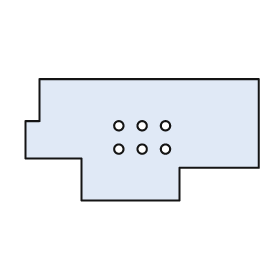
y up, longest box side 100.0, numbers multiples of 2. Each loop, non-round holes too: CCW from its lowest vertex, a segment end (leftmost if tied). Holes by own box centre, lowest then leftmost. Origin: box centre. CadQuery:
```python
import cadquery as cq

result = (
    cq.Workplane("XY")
    .moveTo(-26.0, -26.0)
    .lineTo(16.0, -26.0)
    .lineTo(16.0, -12.0)
    .lineTo(50.0, -12.0)
    .lineTo(50.0, 26.0)
    .lineTo(-44.0, 26.0)
    .lineTo(-44.0, 8.0)
    .lineTo(-50.0, 8.0)
    .lineTo(-50.0, -8.0)
    .lineTo(-26.0, -8.0)
    .close()
    .moveTo(-10.0, -4.0)
    .circle(2.0)
    .moveTo(0.0, -4.0)
    .circle(2.0)
    .moveTo(10.0, -4.0)
    .circle(2.0)
    .moveTo(-10.0, 6.0)
    .circle(2.0)
    .moveTo(0.0, 6.0)
    .circle(2.0)
    .moveTo(10.0, 6.0)
    .circle(2.0)
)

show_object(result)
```